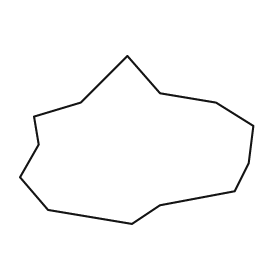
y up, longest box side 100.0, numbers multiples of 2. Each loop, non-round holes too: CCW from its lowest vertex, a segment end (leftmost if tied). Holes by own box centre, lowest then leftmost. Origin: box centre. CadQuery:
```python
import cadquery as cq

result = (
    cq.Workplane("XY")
    .moveTo(-2.0, -36.0)
    .lineTo(10.0, -28.0)
    .lineTo(42.0, -22.0)
    .lineTo(48.0, -10.0)
    .lineTo(50.0, 6.0)
    .lineTo(34.0, 16.0)
    .lineTo(10.0, 20.0)
    .lineTo(-4.0, 36.0)
    .lineTo(-24.0, 16.0)
    .lineTo(-44.0, 10.0)
    .lineTo(-42.0, -2.0)
    .lineTo(-50.0, -16.0)
    .lineTo(-38.0, -30.0)
    .close()
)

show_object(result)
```